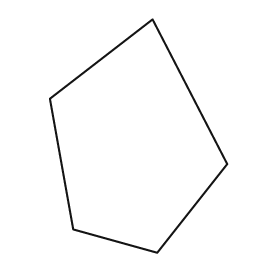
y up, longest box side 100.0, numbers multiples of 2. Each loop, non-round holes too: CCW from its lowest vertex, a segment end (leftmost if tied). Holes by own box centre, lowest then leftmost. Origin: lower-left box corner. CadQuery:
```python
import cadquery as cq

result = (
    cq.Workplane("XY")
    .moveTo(46.0, 0.0)
    .lineTo(76.0, 38.0)
    .lineTo(44.0, 100.0)
    .lineTo(0.0, 66.0)
    .lineTo(10.0, 10.0)
    .close()
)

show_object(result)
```